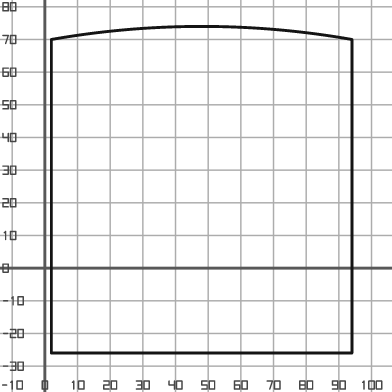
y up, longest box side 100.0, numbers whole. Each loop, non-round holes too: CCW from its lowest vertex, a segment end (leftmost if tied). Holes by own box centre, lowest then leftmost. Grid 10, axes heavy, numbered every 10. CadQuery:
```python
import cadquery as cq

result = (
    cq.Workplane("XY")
    .moveTo(2.0, -26.0)
    .lineTo(94.0, -26.0)
    .lineTo(94.0, 70.0)
    .threePointArc((48.0, 74.0), (2.0, 70.0))
    .close()
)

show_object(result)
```